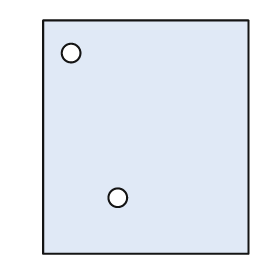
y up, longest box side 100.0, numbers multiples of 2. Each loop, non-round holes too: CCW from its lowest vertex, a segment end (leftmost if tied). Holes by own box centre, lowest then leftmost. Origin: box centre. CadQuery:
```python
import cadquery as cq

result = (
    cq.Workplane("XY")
    .moveTo(-44.0, -50.0)
    .lineTo(44.0, -50.0)
    .lineTo(44.0, 50.0)
    .lineTo(-44.0, 50.0)
    .close()
    .moveTo(-12.0, -26.0)
    .circle(4.0)
    .moveTo(-32.0, 36.0)
    .circle(4.0)
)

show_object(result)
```